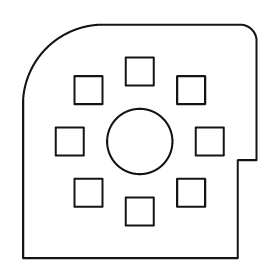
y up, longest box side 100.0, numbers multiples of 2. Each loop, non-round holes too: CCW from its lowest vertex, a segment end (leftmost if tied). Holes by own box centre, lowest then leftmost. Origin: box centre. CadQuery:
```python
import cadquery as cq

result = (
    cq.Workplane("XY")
    .moveTo(-50.0, -50.0)
    .lineTo(42.0, -50.0)
    .lineTo(42.0, -8.0)
    .lineTo(50.0, -8.0)
    .lineTo(50.0, 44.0)
    .threePointArc((48.0, 48.0), (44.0, 50.0))
    .lineTo(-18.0, 50.0)
    .threePointArc((-40.0, 40.0), (-50.0, 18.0))
    .close()
    .moveTo(-6.0, -36.0)
    .lineTo(6.0, -36.0)
    .lineTo(6.0, -24.0)
    .lineTo(-6.0, -24.0)
    .close()
    .moveTo(-28.0, -28.0)
    .lineTo(-16.0, -28.0)
    .lineTo(-16.0, -16.0)
    .lineTo(-28.0, -16.0)
    .close()
    .moveTo(16.0, -28.0)
    .lineTo(28.0, -28.0)
    .lineTo(28.0, -16.0)
    .lineTo(16.0, -16.0)
    .close()
    .moveTo(-36.0, -6.0)
    .lineTo(-24.0, -6.0)
    .lineTo(-24.0, 6.0)
    .lineTo(-36.0, 6.0)
    .close()
    .moveTo(0.0, 0.0)
    .circle(14.0)
    .moveTo(24.0, -6.0)
    .lineTo(36.0, -6.0)
    .lineTo(36.0, 6.0)
    .lineTo(24.0, 6.0)
    .close()
    .moveTo(-28.0, 16.0)
    .lineTo(-16.0, 16.0)
    .lineTo(-16.0, 28.0)
    .lineTo(-28.0, 28.0)
    .close()
    .moveTo(16.0, 16.0)
    .lineTo(28.0, 16.0)
    .lineTo(28.0, 28.0)
    .lineTo(16.0, 28.0)
    .close()
    .moveTo(-6.0, 24.0)
    .lineTo(6.0, 24.0)
    .lineTo(6.0, 36.0)
    .lineTo(-6.0, 36.0)
    .close()
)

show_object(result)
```